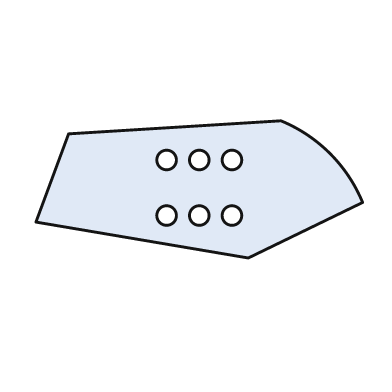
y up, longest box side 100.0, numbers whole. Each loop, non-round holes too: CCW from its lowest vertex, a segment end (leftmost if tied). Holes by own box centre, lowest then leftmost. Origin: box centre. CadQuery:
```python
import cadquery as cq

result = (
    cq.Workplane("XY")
    .moveTo(15.0, -21.0)
    .lineTo(50.0, -4.0)
    .threePointArc((40.0, 11.0), (25.0, 21.0))
    .lineTo(-40.0, 17.0)
    .lineTo(-50.0, -10.0)
    .close()
    .moveTo(-10.0, -8.0)
    .circle(3.0)
    .moveTo(0.0, -8.0)
    .circle(3.0)
    .moveTo(10.0, -8.0)
    .circle(3.0)
    .moveTo(-10.0, 9.0)
    .circle(3.0)
    .moveTo(0.0, 9.0)
    .circle(3.0)
    .moveTo(10.0, 9.0)
    .circle(3.0)
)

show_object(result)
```